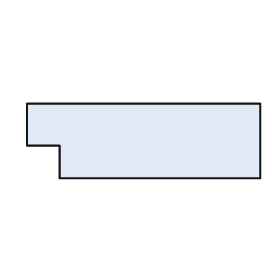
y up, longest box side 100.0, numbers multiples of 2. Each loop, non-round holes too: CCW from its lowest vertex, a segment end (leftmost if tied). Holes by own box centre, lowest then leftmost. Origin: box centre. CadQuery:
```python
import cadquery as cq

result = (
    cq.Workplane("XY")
    .moveTo(-36.0, -16.0)
    .lineTo(50.0, -16.0)
    .lineTo(50.0, 16.0)
    .lineTo(-50.0, 16.0)
    .lineTo(-50.0, -2.0)
    .lineTo(-36.0, -2.0)
    .close()
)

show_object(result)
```